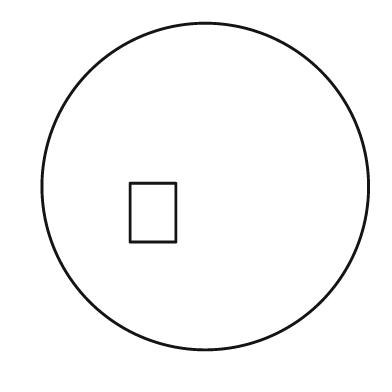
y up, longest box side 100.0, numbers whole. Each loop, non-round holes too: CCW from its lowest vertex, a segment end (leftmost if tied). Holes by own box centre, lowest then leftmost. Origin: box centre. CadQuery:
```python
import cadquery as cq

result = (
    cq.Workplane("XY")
    .moveTo(0.0, 0.0)
    .circle(50.0)
    .moveTo(-23.0, -17.0)
    .lineTo(-9.0, -17.0)
    .lineTo(-9.0, 1.0)
    .lineTo(-23.0, 1.0)
    .close()
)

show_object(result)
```